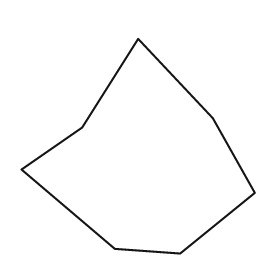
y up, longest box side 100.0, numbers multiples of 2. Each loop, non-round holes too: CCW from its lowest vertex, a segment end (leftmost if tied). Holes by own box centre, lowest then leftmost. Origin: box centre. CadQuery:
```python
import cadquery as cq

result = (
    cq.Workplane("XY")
    .moveTo(18.0, -46.0)
    .lineTo(50.0, -20.0)
    .lineTo(32.0, 12.0)
    .lineTo(0.0, 46.0)
    .lineTo(-24.0, 8.0)
    .lineTo(-50.0, -10.0)
    .lineTo(-10.0, -44.0)
    .close()
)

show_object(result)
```